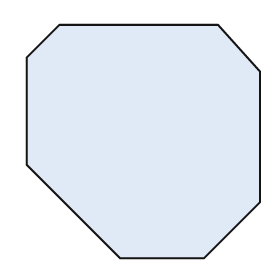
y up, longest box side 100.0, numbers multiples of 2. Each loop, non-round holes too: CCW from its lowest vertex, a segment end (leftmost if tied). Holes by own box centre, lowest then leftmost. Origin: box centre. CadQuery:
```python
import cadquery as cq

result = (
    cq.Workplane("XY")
    .moveTo(-10.0, -50.0)
    .lineTo(26.0, -50.0)
    .lineTo(50.0, -26.0)
    .lineTo(50.0, 30.0)
    .lineTo(32.0, 50.0)
    .lineTo(-36.0, 50.0)
    .lineTo(-50.0, 36.0)
    .lineTo(-50.0, -10.0)
    .close()
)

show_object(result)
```